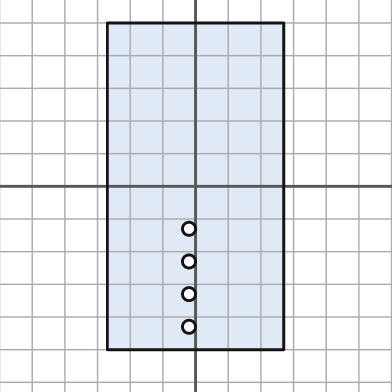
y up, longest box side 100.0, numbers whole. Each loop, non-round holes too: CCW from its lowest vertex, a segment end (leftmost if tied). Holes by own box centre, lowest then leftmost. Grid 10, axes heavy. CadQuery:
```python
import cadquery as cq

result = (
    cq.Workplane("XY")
    .moveTo(-27.0, -50.0)
    .lineTo(27.0, -50.0)
    .lineTo(27.0, 50.0)
    .lineTo(-27.0, 50.0)
    .close()
    .moveTo(-2.0, -43.0)
    .circle(2.0)
    .moveTo(-2.0, -33.0)
    .circle(2.0)
    .moveTo(-2.0, -23.0)
    .circle(2.0)
    .moveTo(-2.0, -13.0)
    .circle(2.0)
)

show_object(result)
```